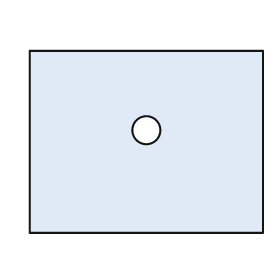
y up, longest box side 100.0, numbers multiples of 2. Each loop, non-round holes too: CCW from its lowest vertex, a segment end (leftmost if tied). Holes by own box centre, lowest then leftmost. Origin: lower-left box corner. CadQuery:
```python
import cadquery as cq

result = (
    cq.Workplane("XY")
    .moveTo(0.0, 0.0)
    .lineTo(100.0, 0.0)
    .lineTo(100.0, 78.0)
    .lineTo(0.0, 78.0)
    .close()
    .moveTo(50.0, 44.0)
    .circle(6.0)
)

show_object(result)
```